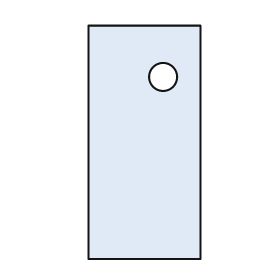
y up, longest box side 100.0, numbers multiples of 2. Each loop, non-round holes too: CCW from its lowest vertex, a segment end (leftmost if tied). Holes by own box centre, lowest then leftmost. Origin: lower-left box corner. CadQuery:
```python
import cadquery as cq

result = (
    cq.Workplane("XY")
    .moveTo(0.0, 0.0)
    .lineTo(48.0, 0.0)
    .lineTo(48.0, 100.0)
    .lineTo(0.0, 100.0)
    .close()
    .moveTo(32.0, 78.0)
    .circle(6.0)
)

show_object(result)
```